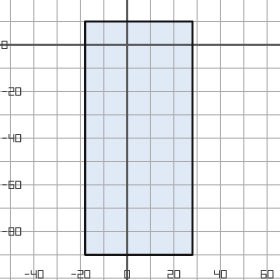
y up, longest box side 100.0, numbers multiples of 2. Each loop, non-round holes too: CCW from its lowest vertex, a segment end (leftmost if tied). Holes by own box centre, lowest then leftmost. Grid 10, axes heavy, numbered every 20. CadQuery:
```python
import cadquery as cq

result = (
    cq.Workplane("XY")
    .moveTo(-18.0, -90.0)
    .lineTo(28.0, -90.0)
    .lineTo(28.0, 10.0)
    .lineTo(-18.0, 10.0)
    .close()
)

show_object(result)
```